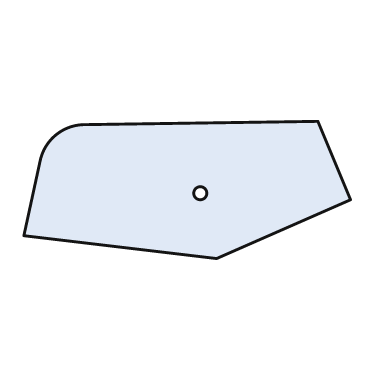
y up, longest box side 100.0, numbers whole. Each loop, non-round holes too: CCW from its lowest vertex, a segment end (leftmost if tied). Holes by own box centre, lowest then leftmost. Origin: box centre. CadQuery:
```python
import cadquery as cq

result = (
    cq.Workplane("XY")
    .moveTo(9.0, -21.0)
    .lineTo(50.0, -3.0)
    .lineTo(40.0, 21.0)
    .lineTo(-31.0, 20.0)
    .threePointArc((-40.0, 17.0), (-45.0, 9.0))
    .lineTo(-50.0, -14.0)
    .close()
    .moveTo(4.0, -1.0)
    .circle(2.0)
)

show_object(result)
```